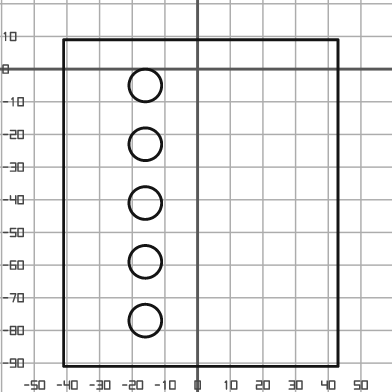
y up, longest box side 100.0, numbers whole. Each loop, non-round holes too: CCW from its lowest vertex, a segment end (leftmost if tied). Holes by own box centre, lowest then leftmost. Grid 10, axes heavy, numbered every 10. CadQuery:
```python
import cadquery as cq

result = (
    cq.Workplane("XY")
    .moveTo(-41.0, -91.0)
    .lineTo(43.0, -91.0)
    .lineTo(43.0, 9.0)
    .lineTo(-41.0, 9.0)
    .close()
    .moveTo(-16.0, -77.0)
    .circle(5.0)
    .moveTo(-16.0, -59.0)
    .circle(5.0)
    .moveTo(-16.0, -41.0)
    .circle(5.0)
    .moveTo(-16.0, -23.0)
    .circle(5.0)
    .moveTo(-16.0, -5.0)
    .circle(5.0)
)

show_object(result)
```